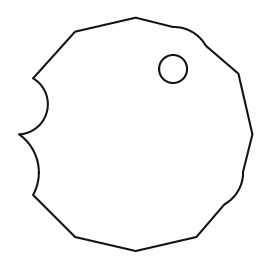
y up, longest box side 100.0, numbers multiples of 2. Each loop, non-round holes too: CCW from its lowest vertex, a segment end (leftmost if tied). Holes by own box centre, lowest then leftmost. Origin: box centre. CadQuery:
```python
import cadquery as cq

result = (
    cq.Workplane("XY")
    .moveTo(0.0, -50.0)
    .lineTo(26.0, -44.0)
    .lineTo(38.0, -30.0)
    .threePointArc((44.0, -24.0), (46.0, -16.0))
    .lineTo(50.0, 0.0)
    .lineTo(44.0, 26.0)
    .lineTo(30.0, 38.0)
    .threePointArc((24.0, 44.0), (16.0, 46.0))
    .lineTo(0.0, 50.0)
    .lineTo(-26.0, 44.0)
    .lineTo(-44.0, 24.0)
    .threePointArc((-38.0, 10.0), (-50.0, 0.0))
    .threePointArc((-42.0, -12.0), (-44.0, -26.0))
    .lineTo(-26.0, -44.0)
    .close()
    .moveTo(16.0, 28.0)
    .circle(6.0)
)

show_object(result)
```